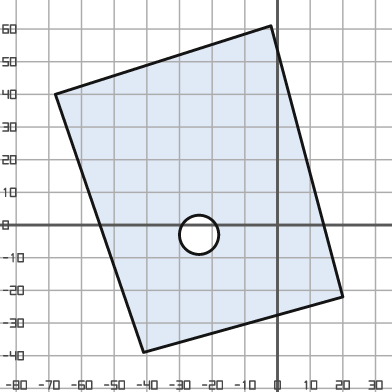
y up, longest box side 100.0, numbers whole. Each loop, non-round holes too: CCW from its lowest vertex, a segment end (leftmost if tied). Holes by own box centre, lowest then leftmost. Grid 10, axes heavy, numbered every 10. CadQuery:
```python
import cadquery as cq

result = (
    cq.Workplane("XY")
    .moveTo(-41.0, -39.0)
    .lineTo(20.0, -22.0)
    .lineTo(-2.0, 61.0)
    .lineTo(-68.0, 40.0)
    .close()
    .moveTo(-24.0, -3.0)
    .circle(6.0)
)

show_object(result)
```